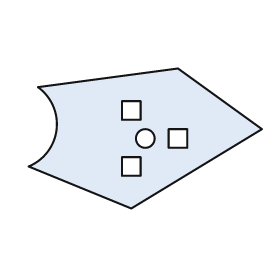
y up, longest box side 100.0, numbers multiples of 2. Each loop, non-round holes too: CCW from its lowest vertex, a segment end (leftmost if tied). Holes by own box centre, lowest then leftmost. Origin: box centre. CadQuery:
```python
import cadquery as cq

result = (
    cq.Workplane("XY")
    .moveTo(-6.0, -30.0)
    .lineTo(50.0, 4.0)
    .lineTo(14.0, 30.0)
    .lineTo(-46.0, 22.0)
    .threePointArc((-38.0, 4.0), (-50.0, -12.0))
    .close()
    .moveTo(-10.0, -16.0)
    .lineTo(-2.0, -16.0)
    .lineTo(-2.0, -8.0)
    .lineTo(-10.0, -8.0)
    .close()
    .moveTo(0.0, 0.0)
    .circle(4.0)
    .moveTo(10.0, -4.0)
    .lineTo(18.0, -4.0)
    .lineTo(18.0, 4.0)
    .lineTo(10.0, 4.0)
    .close()
    .moveTo(-10.0, 8.0)
    .lineTo(-2.0, 8.0)
    .lineTo(-2.0, 16.0)
    .lineTo(-10.0, 16.0)
    .close()
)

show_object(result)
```